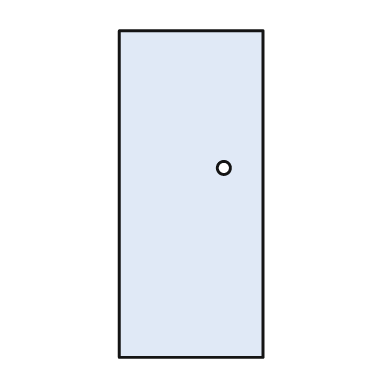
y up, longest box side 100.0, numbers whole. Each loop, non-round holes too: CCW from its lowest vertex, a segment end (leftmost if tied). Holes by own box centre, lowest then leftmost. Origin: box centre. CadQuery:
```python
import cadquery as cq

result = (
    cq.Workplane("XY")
    .moveTo(-22.0, -50.0)
    .lineTo(22.0, -50.0)
    .lineTo(22.0, 50.0)
    .lineTo(-22.0, 50.0)
    .close()
    .moveTo(10.0, 8.0)
    .circle(2.0)
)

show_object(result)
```